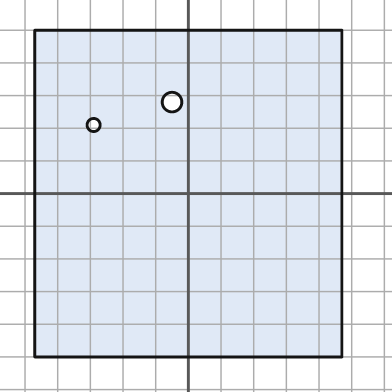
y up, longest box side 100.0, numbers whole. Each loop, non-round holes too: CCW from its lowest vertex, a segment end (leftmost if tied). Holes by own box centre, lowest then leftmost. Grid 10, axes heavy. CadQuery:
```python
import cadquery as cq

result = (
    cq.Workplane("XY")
    .moveTo(-47.0, -50.0)
    .lineTo(47.0, -50.0)
    .lineTo(47.0, 50.0)
    .lineTo(-47.0, 50.0)
    .close()
    .moveTo(-29.0, 21.0)
    .circle(2.0)
    .moveTo(-5.0, 28.0)
    .circle(3.0)
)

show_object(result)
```